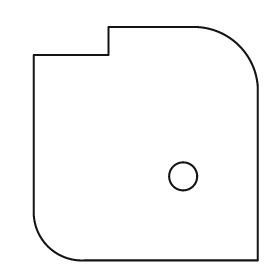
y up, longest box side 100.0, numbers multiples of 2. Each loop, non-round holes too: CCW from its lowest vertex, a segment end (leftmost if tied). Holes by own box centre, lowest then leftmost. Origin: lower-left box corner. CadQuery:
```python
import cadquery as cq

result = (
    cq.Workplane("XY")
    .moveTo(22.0, 0.0)
    .lineTo(96.0, 0.0)
    .lineTo(96.0, 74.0)
    .threePointArc((88.0, 92.0), (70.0, 100.0))
    .lineTo(32.0, 100.0)
    .lineTo(32.0, 88.0)
    .lineTo(0.0, 88.0)
    .lineTo(0.0, 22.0)
    .threePointArc((6.0, 6.0), (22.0, 0.0))
    .close()
    .moveTo(64.0, 36.0)
    .circle(6.0)
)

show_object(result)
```